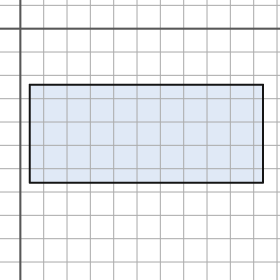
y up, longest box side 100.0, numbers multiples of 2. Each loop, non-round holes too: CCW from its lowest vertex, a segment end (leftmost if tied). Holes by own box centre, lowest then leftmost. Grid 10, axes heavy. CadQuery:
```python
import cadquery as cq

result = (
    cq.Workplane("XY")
    .moveTo(4.0, -66.0)
    .lineTo(104.0, -66.0)
    .lineTo(104.0, -24.0)
    .lineTo(4.0, -24.0)
    .close()
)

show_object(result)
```